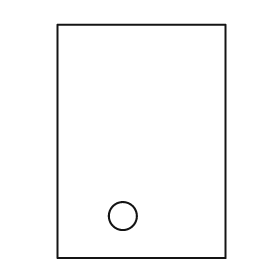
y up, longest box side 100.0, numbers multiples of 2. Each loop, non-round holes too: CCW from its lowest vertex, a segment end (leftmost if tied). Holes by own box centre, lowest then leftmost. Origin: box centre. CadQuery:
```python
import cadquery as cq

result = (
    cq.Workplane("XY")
    .moveTo(-36.0, -50.0)
    .lineTo(36.0, -50.0)
    .lineTo(36.0, 50.0)
    .lineTo(-36.0, 50.0)
    .close()
    .moveTo(-8.0, -32.0)
    .circle(6.0)
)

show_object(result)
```